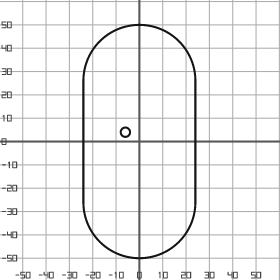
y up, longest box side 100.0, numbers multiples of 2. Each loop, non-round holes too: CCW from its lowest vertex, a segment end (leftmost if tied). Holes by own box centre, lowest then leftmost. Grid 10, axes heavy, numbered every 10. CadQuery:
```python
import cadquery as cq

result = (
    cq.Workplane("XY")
    .moveTo(-24.0, -26.0)
    .threePointArc((0.0, -50.0), (24.0, -26.0))
    .lineTo(24.0, 26.0)
    .threePointArc((0.0, 50.0), (-24.0, 26.0))
    .close()
    .moveTo(-6.0, 4.0)
    .circle(2.0)
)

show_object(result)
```